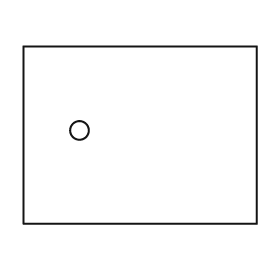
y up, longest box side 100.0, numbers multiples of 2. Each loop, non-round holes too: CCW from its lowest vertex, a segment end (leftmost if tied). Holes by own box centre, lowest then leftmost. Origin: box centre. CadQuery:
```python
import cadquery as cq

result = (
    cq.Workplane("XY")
    .moveTo(-50.0, -38.0)
    .lineTo(50.0, -38.0)
    .lineTo(50.0, 38.0)
    .lineTo(-50.0, 38.0)
    .close()
    .moveTo(-26.0, 2.0)
    .circle(4.0)
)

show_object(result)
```